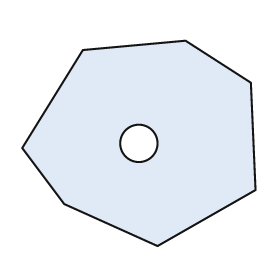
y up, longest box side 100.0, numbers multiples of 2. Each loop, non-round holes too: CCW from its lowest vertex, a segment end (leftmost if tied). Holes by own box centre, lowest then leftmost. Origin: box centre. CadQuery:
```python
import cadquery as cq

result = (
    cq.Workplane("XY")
    .moveTo(8.0, -44.0)
    .lineTo(50.0, -20.0)
    .lineTo(48.0, 26.0)
    .lineTo(20.0, 44.0)
    .lineTo(-24.0, 40.0)
    .lineTo(-50.0, -2.0)
    .lineTo(-32.0, -26.0)
    .close()
    .moveTo(0.0, 0.0)
    .circle(8.0)
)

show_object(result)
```